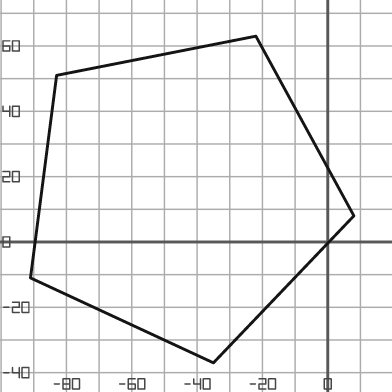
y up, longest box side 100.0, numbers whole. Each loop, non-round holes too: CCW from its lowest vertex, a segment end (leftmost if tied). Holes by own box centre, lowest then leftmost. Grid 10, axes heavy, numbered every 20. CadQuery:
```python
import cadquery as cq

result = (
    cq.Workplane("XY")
    .moveTo(-35.0, -37.0)
    .lineTo(8.0, 8.0)
    .lineTo(-22.0, 63.0)
    .lineTo(-83.0, 51.0)
    .lineTo(-91.0, -11.0)
    .close()
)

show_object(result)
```